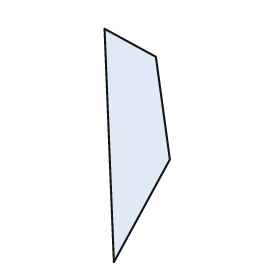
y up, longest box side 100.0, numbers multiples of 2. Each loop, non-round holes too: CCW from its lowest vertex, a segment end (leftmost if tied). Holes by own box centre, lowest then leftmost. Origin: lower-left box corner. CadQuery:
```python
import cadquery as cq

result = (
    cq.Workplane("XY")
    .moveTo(4.0, 0.0)
    .lineTo(28.0, 44.0)
    .lineTo(22.0, 88.0)
    .lineTo(0.0, 100.0)
    .close()
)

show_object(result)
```